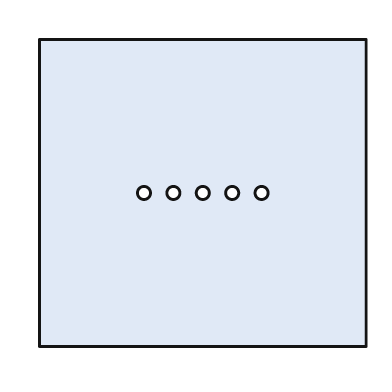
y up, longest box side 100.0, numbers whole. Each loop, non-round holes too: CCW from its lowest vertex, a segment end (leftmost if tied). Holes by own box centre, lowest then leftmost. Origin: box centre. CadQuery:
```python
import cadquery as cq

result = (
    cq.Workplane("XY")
    .moveTo(-50.0, -47.0)
    .lineTo(50.0, -47.0)
    .lineTo(50.0, 47.0)
    .lineTo(-50.0, 47.0)
    .close()
    .moveTo(-18.0, 0.0)
    .circle(2.0)
    .moveTo(-9.0, 0.0)
    .circle(2.0)
    .moveTo(0.0, 0.0)
    .circle(2.0)
    .moveTo(9.0, 0.0)
    .circle(2.0)
    .moveTo(18.0, 0.0)
    .circle(2.0)
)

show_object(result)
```